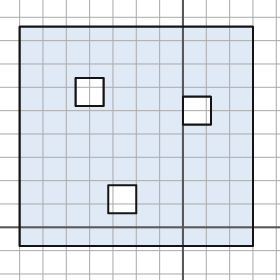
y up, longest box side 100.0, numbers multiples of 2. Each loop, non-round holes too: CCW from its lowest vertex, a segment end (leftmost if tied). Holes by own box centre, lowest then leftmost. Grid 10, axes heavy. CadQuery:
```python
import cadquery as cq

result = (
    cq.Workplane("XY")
    .moveTo(-70.0, -8.0)
    .lineTo(30.0, -8.0)
    .lineTo(30.0, 86.0)
    .lineTo(-70.0, 86.0)
    .close()
    .moveTo(-32.0, 6.0)
    .lineTo(-20.0, 6.0)
    .lineTo(-20.0, 18.0)
    .lineTo(-32.0, 18.0)
    .close()
    .moveTo(0.0, 44.0)
    .lineTo(12.0, 44.0)
    .lineTo(12.0, 56.0)
    .lineTo(0.0, 56.0)
    .close()
    .moveTo(-46.0, 52.0)
    .lineTo(-34.0, 52.0)
    .lineTo(-34.0, 64.0)
    .lineTo(-46.0, 64.0)
    .close()
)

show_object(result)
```